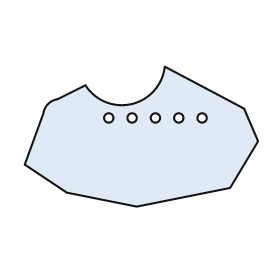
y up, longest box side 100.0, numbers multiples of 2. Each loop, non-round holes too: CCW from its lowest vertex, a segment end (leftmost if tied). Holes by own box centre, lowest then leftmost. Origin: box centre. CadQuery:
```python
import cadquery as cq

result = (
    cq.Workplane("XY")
    .moveTo(-2.0, -30.0)
    .lineTo(38.0, -22.0)
    .lineTo(50.0, -2.0)
    .lineTo(44.0, 12.0)
    .lineTo(10.0, 30.0)
    .threePointArc((-4.0, 14.0), (-24.0, 22.0))
    .lineTo(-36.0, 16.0)
    .threePointArc((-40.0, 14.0), (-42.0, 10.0))
    .lineTo(-50.0, -12.0)
    .lineTo(-32.0, -24.0)
    .close()
    .moveTo(-14.0, 8.0)
    .circle(2.0)
    .moveTo(-4.0, 8.0)
    .circle(2.0)
    .moveTo(6.0, 8.0)
    .circle(2.0)
    .moveTo(16.0, 8.0)
    .circle(2.0)
    .moveTo(26.0, 8.0)
    .circle(2.0)
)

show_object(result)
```